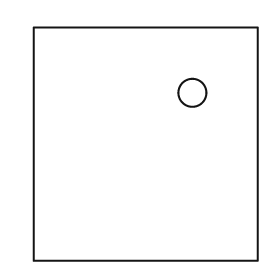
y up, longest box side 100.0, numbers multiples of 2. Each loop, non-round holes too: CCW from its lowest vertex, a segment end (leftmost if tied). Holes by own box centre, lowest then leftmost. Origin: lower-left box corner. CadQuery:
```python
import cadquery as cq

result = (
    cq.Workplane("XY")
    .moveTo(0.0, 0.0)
    .lineTo(96.0, 0.0)
    .lineTo(96.0, 100.0)
    .lineTo(0.0, 100.0)
    .close()
    .moveTo(68.0, 72.0)
    .circle(6.0)
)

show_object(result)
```